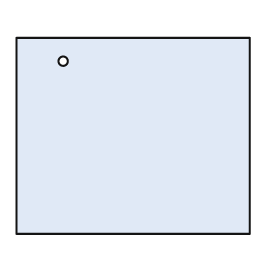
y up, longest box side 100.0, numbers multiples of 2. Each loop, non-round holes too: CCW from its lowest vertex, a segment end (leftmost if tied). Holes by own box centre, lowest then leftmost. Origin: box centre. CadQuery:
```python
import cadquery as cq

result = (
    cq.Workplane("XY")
    .moveTo(-50.0, -42.0)
    .lineTo(50.0, -42.0)
    .lineTo(50.0, 42.0)
    .lineTo(-50.0, 42.0)
    .close()
    .moveTo(-30.0, 32.0)
    .circle(2.0)
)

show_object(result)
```